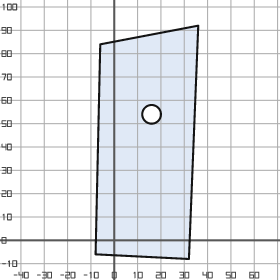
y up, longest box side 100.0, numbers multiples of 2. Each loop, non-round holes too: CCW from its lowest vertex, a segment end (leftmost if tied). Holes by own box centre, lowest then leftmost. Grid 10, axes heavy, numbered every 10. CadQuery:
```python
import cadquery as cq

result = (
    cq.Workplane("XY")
    .moveTo(32.0, -8.0)
    .lineTo(36.0, 92.0)
    .lineTo(-6.0, 84.0)
    .lineTo(-8.0, -6.0)
    .close()
    .moveTo(16.0, 54.0)
    .circle(4.0)
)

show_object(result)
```